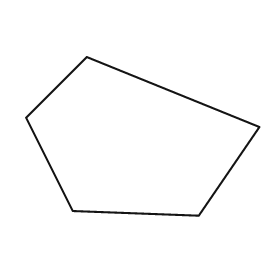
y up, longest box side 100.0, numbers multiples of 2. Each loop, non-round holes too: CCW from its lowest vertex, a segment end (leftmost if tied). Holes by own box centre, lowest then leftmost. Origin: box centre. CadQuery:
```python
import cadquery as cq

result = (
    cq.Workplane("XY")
    .moveTo(24.0, -34.0)
    .lineTo(50.0, 4.0)
    .lineTo(-24.0, 34.0)
    .lineTo(-50.0, 8.0)
    .lineTo(-30.0, -32.0)
    .close()
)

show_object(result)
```